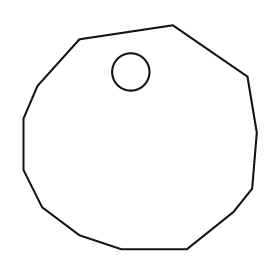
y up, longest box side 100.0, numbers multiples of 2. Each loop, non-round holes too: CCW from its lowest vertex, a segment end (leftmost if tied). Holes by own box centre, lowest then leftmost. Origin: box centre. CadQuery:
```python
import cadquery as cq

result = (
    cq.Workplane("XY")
    .moveTo(-8.0, -48.0)
    .lineTo(20.0, -48.0)
    .lineTo(40.0, -32.0)
    .lineTo(48.0, -22.0)
    .lineTo(50.0, 2.0)
    .lineTo(46.0, 26.0)
    .lineTo(14.0, 48.0)
    .lineTo(-26.0, 42.0)
    .lineTo(-44.0, 22.0)
    .lineTo(-50.0, 8.0)
    .lineTo(-50.0, -14.0)
    .lineTo(-42.0, -30.0)
    .lineTo(-26.0, -42.0)
    .close()
    .moveTo(-4.0, 28.0)
    .circle(8.0)
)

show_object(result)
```